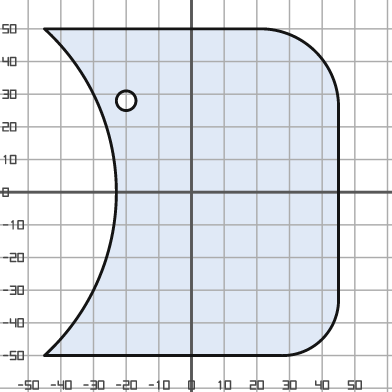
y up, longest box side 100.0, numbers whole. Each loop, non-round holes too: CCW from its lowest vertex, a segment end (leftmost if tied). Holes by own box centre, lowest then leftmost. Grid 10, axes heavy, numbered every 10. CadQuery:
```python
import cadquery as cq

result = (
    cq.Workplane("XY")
    .moveTo(-45.0, -50.0)
    .lineTo(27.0, -50.0)
    .threePointArc((40.0, -45.0), (45.0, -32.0))
    .lineTo(45.0, 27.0)
    .threePointArc((38.0, 43.0), (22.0, 50.0))
    .lineTo(-45.0, 50.0)
    .threePointArc((-23.0, 0.0), (-45.0, -50.0))
    .close()
    .moveTo(-20.0, 28.0)
    .circle(3.0)
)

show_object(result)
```